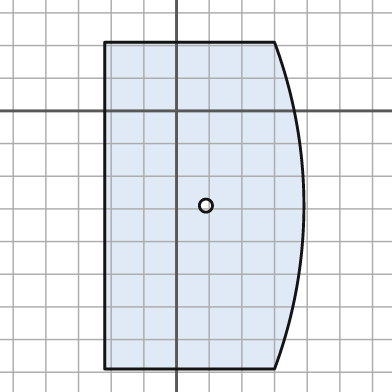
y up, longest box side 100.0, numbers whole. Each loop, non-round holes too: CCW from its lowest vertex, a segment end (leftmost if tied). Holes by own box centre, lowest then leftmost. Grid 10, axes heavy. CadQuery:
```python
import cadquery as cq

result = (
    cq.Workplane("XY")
    .moveTo(-22.0, -79.0)
    .lineTo(30.0, -79.0)
    .threePointArc((39.0, -29.0), (30.0, 21.0))
    .lineTo(-22.0, 21.0)
    .close()
    .moveTo(9.0, -29.0)
    .circle(2.0)
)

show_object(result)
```